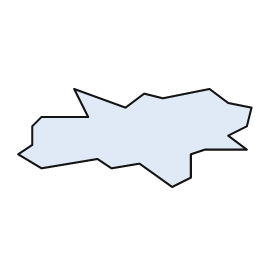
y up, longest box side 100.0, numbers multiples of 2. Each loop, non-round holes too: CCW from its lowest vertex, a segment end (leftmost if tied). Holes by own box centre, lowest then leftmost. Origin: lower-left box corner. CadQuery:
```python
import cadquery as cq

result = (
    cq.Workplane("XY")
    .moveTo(66.0, 0.0)
    .lineTo(74.0, 4.0)
    .lineTo(74.0, 14.0)
    .lineTo(80.0, 16.0)
    .lineTo(98.0, 16.0)
    .lineTo(90.0, 22.0)
    .lineTo(98.0, 26.0)
    .lineTo(100.0, 34.0)
    .lineTo(90.0, 36.0)
    .lineTo(82.0, 42.0)
    .lineTo(62.0, 38.0)
    .lineTo(54.0, 40.0)
    .lineTo(46.0, 34.0)
    .lineTo(24.0, 42.0)
    .lineTo(30.0, 30.0)
    .lineTo(10.0, 30.0)
    .lineTo(6.0, 26.0)
    .lineTo(6.0, 18.0)
    .lineTo(0.0, 14.0)
    .lineTo(10.0, 8.0)
    .lineTo(34.0, 12.0)
    .lineTo(40.0, 8.0)
    .lineTo(52.0, 10.0)
    .close()
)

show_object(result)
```